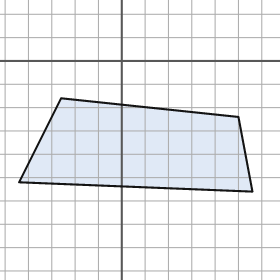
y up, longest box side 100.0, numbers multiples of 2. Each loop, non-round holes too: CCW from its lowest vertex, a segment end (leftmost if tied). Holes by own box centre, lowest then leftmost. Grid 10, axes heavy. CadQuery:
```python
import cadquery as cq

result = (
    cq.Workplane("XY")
    .moveTo(56.0, -56.0)
    .lineTo(50.0, -24.0)
    .lineTo(-26.0, -16.0)
    .lineTo(-44.0, -52.0)
    .close()
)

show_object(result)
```